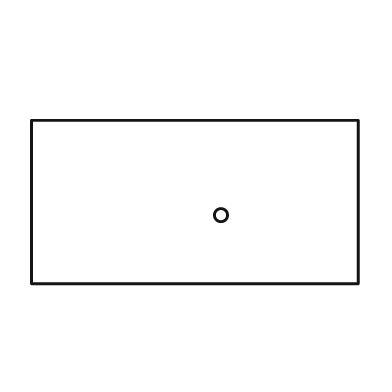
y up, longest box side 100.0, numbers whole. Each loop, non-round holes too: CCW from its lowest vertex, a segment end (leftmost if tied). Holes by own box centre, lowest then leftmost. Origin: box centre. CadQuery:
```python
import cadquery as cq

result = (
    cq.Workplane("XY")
    .moveTo(-50.0, -25.0)
    .lineTo(50.0, -25.0)
    .lineTo(50.0, 25.0)
    .lineTo(-50.0, 25.0)
    .close()
    .moveTo(8.0, -4.0)
    .circle(2.0)
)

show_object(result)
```